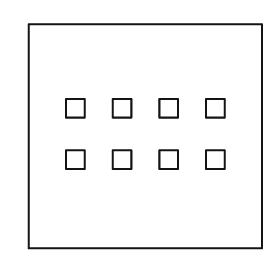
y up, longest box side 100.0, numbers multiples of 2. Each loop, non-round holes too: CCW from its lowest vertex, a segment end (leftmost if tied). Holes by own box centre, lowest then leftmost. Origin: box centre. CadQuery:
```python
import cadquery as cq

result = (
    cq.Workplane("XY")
    .moveTo(-50.0, -48.0)
    .lineTo(50.0, -48.0)
    .lineTo(50.0, 48.0)
    .lineTo(-50.0, 48.0)
    .close()
    .moveTo(-34.0, -14.0)
    .lineTo(-26.0, -14.0)
    .lineTo(-26.0, -6.0)
    .lineTo(-34.0, -6.0)
    .close()
    .moveTo(-14.0, -14.0)
    .lineTo(-6.0, -14.0)
    .lineTo(-6.0, -6.0)
    .lineTo(-14.0, -6.0)
    .close()
    .moveTo(6.0, -14.0)
    .lineTo(14.0, -14.0)
    .lineTo(14.0, -6.0)
    .lineTo(6.0, -6.0)
    .close()
    .moveTo(26.0, -14.0)
    .lineTo(34.0, -14.0)
    .lineTo(34.0, -6.0)
    .lineTo(26.0, -6.0)
    .close()
    .moveTo(-34.0, 8.0)
    .lineTo(-26.0, 8.0)
    .lineTo(-26.0, 16.0)
    .lineTo(-34.0, 16.0)
    .close()
    .moveTo(-14.0, 8.0)
    .lineTo(-6.0, 8.0)
    .lineTo(-6.0, 16.0)
    .lineTo(-14.0, 16.0)
    .close()
    .moveTo(6.0, 8.0)
    .lineTo(14.0, 8.0)
    .lineTo(14.0, 16.0)
    .lineTo(6.0, 16.0)
    .close()
    .moveTo(26.0, 8.0)
    .lineTo(34.0, 8.0)
    .lineTo(34.0, 16.0)
    .lineTo(26.0, 16.0)
    .close()
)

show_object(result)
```